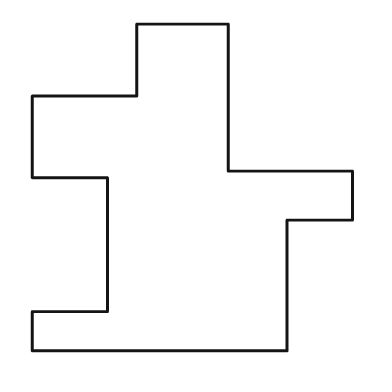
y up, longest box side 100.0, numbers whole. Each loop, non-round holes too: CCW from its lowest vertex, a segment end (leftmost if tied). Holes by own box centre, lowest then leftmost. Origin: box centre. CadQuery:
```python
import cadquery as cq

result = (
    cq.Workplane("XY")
    .moveTo(-49.0, -50.0)
    .lineTo(29.0, -50.0)
    .lineTo(29.0, -10.0)
    .lineTo(49.0, -10.0)
    .lineTo(49.0, 5.0)
    .lineTo(11.0, 5.0)
    .lineTo(11.0, 50.0)
    .lineTo(-17.0, 50.0)
    .lineTo(-17.0, 28.0)
    .lineTo(-49.0, 28.0)
    .lineTo(-49.0, 3.0)
    .lineTo(-26.0, 3.0)
    .lineTo(-26.0, -38.0)
    .lineTo(-49.0, -38.0)
    .close()
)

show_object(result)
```